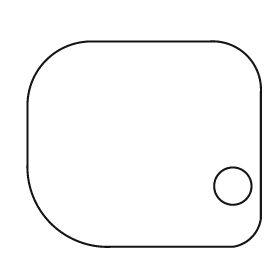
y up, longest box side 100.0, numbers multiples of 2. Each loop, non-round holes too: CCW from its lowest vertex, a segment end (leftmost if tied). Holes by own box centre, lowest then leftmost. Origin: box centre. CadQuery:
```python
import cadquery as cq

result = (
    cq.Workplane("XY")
    .moveTo(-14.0, -44.0)
    .lineTo(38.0, -44.0)
    .threePointArc((46.0, -40.0), (50.0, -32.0))
    .lineTo(50.0, 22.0)
    .threePointArc((44.0, 38.0), (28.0, 44.0))
    .lineTo(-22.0, 44.0)
    .threePointArc((-42.0, 36.0), (-50.0, 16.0))
    .lineTo(-50.0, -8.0)
    .threePointArc((-40.0, -34.0), (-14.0, -44.0))
    .close()
    .moveTo(38.0, -18.0)
    .circle(8.0)
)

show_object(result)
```